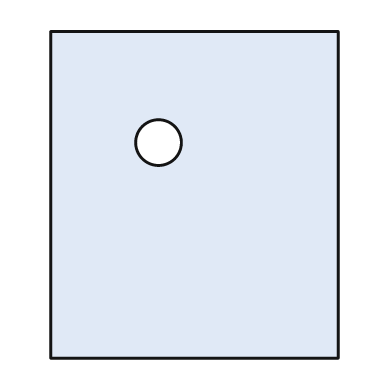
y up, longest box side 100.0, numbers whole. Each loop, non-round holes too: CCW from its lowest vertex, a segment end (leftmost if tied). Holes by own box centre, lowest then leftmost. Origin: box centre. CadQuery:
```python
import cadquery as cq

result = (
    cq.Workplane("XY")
    .moveTo(-44.0, -50.0)
    .lineTo(44.0, -50.0)
    .lineTo(44.0, 50.0)
    .lineTo(-44.0, 50.0)
    .close()
    .moveTo(-11.0, 16.0)
    .circle(7.0)
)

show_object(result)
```